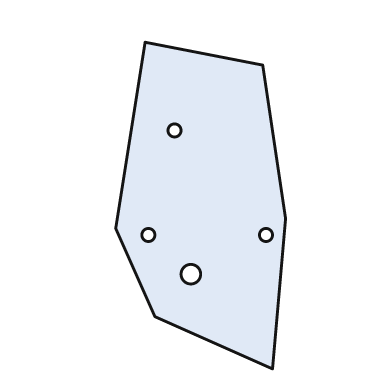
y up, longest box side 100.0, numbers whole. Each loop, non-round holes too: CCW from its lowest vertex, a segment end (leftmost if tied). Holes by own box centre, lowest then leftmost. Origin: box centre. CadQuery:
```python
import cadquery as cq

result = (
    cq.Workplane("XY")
    .moveTo(22.0, -50.0)
    .lineTo(26.0, -4.0)
    .lineTo(19.0, 43.0)
    .lineTo(-17.0, 50.0)
    .lineTo(-26.0, -7.0)
    .lineTo(-14.0, -34.0)
    .close()
    .moveTo(-3.0, -21.0)
    .circle(3.0)
    .moveTo(-16.0, -9.0)
    .circle(2.0)
    .moveTo(20.0, -9.0)
    .circle(2.0)
    .moveTo(-8.0, 23.0)
    .circle(2.0)
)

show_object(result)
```